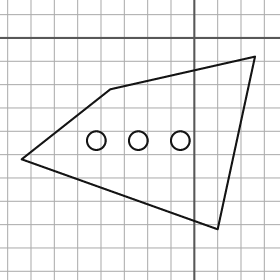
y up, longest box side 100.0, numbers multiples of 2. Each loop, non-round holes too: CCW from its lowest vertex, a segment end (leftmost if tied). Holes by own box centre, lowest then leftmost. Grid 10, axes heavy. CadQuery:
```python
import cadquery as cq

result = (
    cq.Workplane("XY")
    .moveTo(10.0, -82.0)
    .lineTo(26.0, -8.0)
    .lineTo(-36.0, -22.0)
    .lineTo(-74.0, -52.0)
    .close()
    .moveTo(-42.0, -44.0)
    .circle(4.0)
    .moveTo(-24.0, -44.0)
    .circle(4.0)
    .moveTo(-6.0, -44.0)
    .circle(4.0)
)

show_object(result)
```